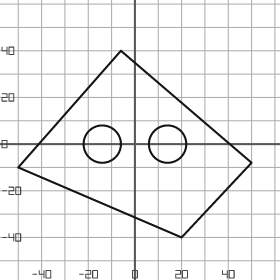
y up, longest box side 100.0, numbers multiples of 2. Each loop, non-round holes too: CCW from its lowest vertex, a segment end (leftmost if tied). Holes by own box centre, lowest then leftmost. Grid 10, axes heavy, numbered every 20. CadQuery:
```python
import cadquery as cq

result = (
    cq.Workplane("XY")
    .moveTo(20.0, -40.0)
    .lineTo(50.0, -8.0)
    .lineTo(-6.0, 40.0)
    .lineTo(-50.0, -10.0)
    .close()
    .moveTo(-14.0, 0.0)
    .circle(8.0)
    .moveTo(14.0, 0.0)
    .circle(8.0)
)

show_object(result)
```